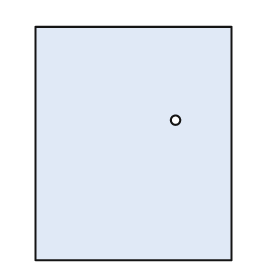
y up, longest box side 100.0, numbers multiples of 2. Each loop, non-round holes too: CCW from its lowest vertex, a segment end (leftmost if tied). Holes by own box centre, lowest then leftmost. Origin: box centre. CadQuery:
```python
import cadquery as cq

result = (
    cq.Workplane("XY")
    .moveTo(-42.0, -50.0)
    .lineTo(42.0, -50.0)
    .lineTo(42.0, 50.0)
    .lineTo(-42.0, 50.0)
    .close()
    .moveTo(18.0, 10.0)
    .circle(2.0)
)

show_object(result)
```